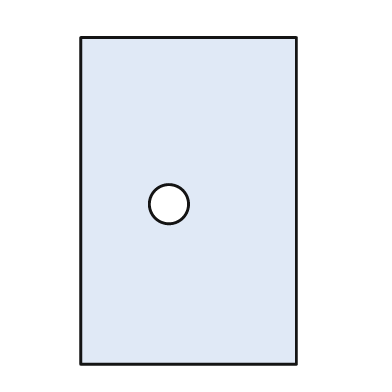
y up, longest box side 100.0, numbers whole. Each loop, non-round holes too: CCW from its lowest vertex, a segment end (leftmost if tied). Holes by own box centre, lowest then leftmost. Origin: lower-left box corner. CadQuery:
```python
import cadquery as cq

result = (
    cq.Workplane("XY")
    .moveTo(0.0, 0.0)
    .lineTo(66.0, 0.0)
    .lineTo(66.0, 100.0)
    .lineTo(0.0, 100.0)
    .close()
    .moveTo(27.0, 49.0)
    .circle(6.0)
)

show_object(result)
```